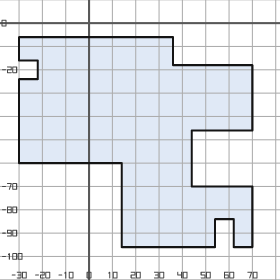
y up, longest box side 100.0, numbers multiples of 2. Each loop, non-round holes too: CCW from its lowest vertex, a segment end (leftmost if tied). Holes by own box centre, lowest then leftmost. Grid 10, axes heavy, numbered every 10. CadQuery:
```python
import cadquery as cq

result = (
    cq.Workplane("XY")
    .moveTo(14.0, -96.0)
    .lineTo(54.0, -96.0)
    .lineTo(54.0, -84.0)
    .lineTo(62.0, -84.0)
    .lineTo(62.0, -96.0)
    .lineTo(70.0, -96.0)
    .lineTo(70.0, -70.0)
    .lineTo(44.0, -70.0)
    .lineTo(44.0, -46.0)
    .lineTo(70.0, -46.0)
    .lineTo(70.0, -18.0)
    .lineTo(36.0, -18.0)
    .lineTo(36.0, -6.0)
    .lineTo(-30.0, -6.0)
    .lineTo(-30.0, -16.0)
    .lineTo(-22.0, -16.0)
    .lineTo(-22.0, -24.0)
    .lineTo(-30.0, -24.0)
    .lineTo(-30.0, -60.0)
    .lineTo(14.0, -60.0)
    .close()
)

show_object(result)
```